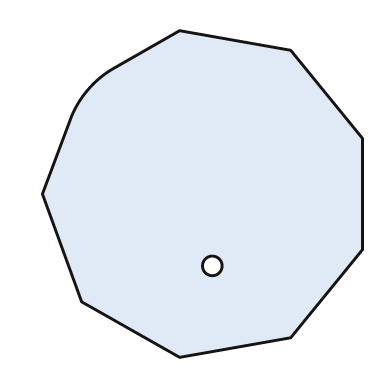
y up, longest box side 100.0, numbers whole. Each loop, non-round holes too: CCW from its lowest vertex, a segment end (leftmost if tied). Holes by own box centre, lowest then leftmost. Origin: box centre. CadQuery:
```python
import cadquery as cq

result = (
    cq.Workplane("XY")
    .moveTo(-7.0, -50.0)
    .lineTo(27.0, -44.0)
    .lineTo(49.0, -17.0)
    .lineTo(49.0, 17.0)
    .lineTo(27.0, 44.0)
    .lineTo(-7.0, 50.0)
    .lineTo(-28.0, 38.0)
    .threePointArc((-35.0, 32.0), (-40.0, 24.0))
    .lineTo(-49.0, 0.0)
    .lineTo(-37.0, -33.0)
    .close()
    .moveTo(3.0, -22.0)
    .circle(3.0)
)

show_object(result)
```